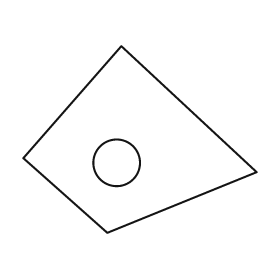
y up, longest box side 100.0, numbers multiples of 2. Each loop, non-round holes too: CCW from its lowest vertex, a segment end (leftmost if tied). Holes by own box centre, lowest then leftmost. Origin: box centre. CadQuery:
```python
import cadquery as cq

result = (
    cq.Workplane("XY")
    .moveTo(-14.0, -40.0)
    .lineTo(50.0, -14.0)
    .lineTo(-8.0, 40.0)
    .lineTo(-50.0, -8.0)
    .close()
    .moveTo(-10.0, -10.0)
    .circle(10.0)
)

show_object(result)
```